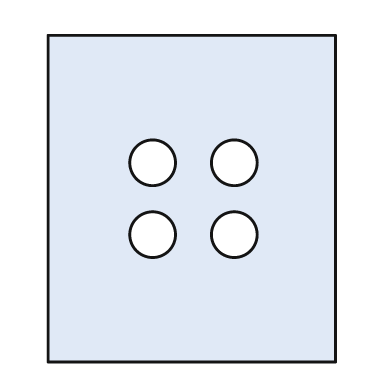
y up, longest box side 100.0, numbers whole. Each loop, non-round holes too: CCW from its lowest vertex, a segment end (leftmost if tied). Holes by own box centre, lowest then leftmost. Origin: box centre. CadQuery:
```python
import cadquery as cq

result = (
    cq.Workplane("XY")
    .moveTo(-44.0, -50.0)
    .lineTo(44.0, -50.0)
    .lineTo(44.0, 50.0)
    .lineTo(-44.0, 50.0)
    .close()
    .moveTo(-12.0, -11.0)
    .circle(7.0)
    .moveTo(13.0, -11.0)
    .circle(7.0)
    .moveTo(-12.0, 11.0)
    .circle(7.0)
    .moveTo(13.0, 11.0)
    .circle(7.0)
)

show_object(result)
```